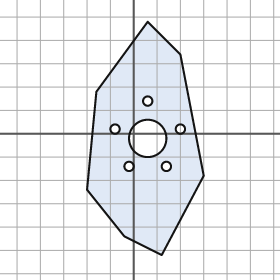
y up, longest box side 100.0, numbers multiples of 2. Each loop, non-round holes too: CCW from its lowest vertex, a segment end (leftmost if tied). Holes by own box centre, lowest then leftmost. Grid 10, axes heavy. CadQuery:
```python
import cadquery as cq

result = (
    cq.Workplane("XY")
    .moveTo(12.0, -52.0)
    .lineTo(30.0, -18.0)
    .lineTo(20.0, 34.0)
    .lineTo(6.0, 48.0)
    .lineTo(-16.0, 18.0)
    .lineTo(-20.0, -24.0)
    .lineTo(-4.0, -44.0)
    .close()
    .moveTo(-2.0, -14.0)
    .circle(2.0)
    .moveTo(14.0, -14.0)
    .circle(2.0)
    .moveTo(6.0, -2.0)
    .circle(8.0)
    .moveTo(-8.0, 2.0)
    .circle(2.0)
    .moveTo(20.0, 2.0)
    .circle(2.0)
    .moveTo(6.0, 14.0)
    .circle(2.0)
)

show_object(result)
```